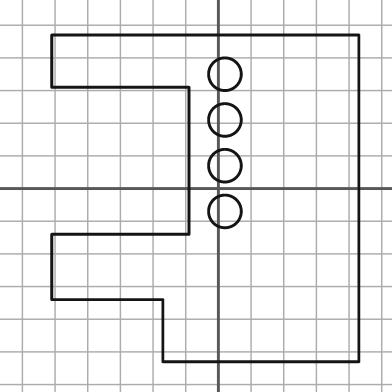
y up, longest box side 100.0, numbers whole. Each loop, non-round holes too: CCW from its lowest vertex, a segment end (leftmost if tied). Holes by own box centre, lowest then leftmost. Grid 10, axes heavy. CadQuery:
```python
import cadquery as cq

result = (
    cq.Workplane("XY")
    .moveTo(-17.0, -53.0)
    .lineTo(43.0, -53.0)
    .lineTo(43.0, 47.0)
    .lineTo(-51.0, 47.0)
    .lineTo(-51.0, 31.0)
    .lineTo(-9.0, 31.0)
    .lineTo(-9.0, -14.0)
    .lineTo(-51.0, -14.0)
    .lineTo(-51.0, -34.0)
    .lineTo(-17.0, -34.0)
    .close()
    .moveTo(2.0, -7.0)
    .circle(5.0)
    .moveTo(2.0, 7.0)
    .circle(5.0)
    .moveTo(2.0, 21.0)
    .circle(5.0)
    .moveTo(2.0, 35.0)
    .circle(5.0)
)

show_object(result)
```